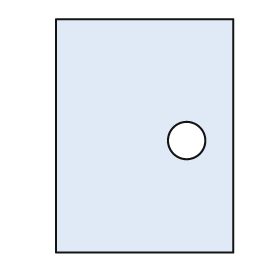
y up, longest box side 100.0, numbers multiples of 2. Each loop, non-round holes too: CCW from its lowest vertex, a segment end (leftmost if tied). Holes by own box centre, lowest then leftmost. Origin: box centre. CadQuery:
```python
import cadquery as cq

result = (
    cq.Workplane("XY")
    .moveTo(-38.0, -50.0)
    .lineTo(38.0, -50.0)
    .lineTo(38.0, 50.0)
    .lineTo(-38.0, 50.0)
    .close()
    .moveTo(18.0, -2.0)
    .circle(8.0)
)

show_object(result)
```